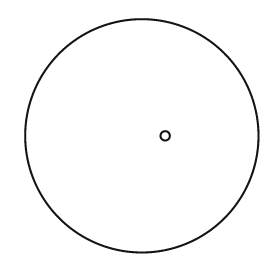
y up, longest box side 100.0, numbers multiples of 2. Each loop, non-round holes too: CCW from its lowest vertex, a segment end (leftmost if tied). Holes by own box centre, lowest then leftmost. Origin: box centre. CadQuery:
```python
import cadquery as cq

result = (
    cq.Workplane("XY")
    .moveTo(0.0, 0.0)
    .circle(50.0)
    .moveTo(10.0, 0.0)
    .circle(2.0)
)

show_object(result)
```